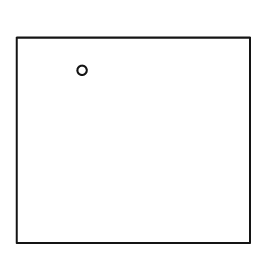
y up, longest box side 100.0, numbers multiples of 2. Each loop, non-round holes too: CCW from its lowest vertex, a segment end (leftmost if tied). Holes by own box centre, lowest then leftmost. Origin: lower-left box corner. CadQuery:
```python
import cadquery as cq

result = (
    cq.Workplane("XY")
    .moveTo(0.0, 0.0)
    .lineTo(100.0, 0.0)
    .lineTo(100.0, 88.0)
    .lineTo(0.0, 88.0)
    .close()
    .moveTo(28.0, 74.0)
    .circle(2.0)
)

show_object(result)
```